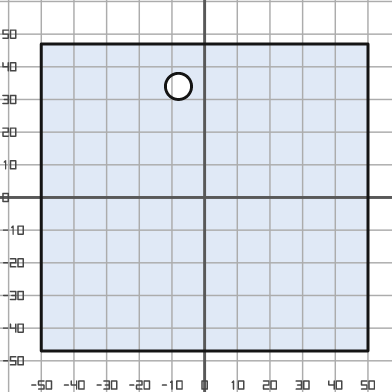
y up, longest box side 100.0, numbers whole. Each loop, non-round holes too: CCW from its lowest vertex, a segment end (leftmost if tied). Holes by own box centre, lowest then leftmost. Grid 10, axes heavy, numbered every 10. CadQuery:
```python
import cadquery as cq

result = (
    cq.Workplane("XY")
    .moveTo(-50.0, -47.0)
    .lineTo(50.0, -47.0)
    .lineTo(50.0, 47.0)
    .lineTo(-50.0, 47.0)
    .close()
    .moveTo(-8.0, 34.0)
    .circle(4.0)
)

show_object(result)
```